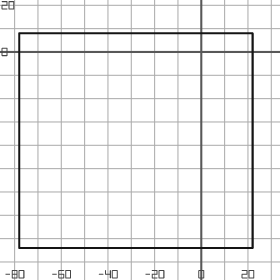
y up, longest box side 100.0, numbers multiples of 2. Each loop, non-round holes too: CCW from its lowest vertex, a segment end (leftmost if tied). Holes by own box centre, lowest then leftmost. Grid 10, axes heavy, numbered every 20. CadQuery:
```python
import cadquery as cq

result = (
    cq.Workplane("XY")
    .moveTo(-78.0, -84.0)
    .lineTo(22.0, -84.0)
    .lineTo(22.0, 8.0)
    .lineTo(-78.0, 8.0)
    .close()
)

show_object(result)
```